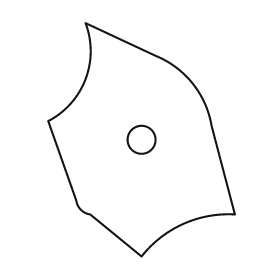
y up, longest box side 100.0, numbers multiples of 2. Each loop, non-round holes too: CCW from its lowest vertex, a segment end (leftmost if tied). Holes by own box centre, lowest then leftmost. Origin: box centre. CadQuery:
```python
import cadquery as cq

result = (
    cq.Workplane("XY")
    .moveTo(0.0, -50.0)
    .threePointArc((18.0, -36.0), (40.0, -32.0))
    .lineTo(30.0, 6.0)
    .threePointArc((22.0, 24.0), (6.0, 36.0))
    .lineTo(-24.0, 50.0)
    .threePointArc((-24.0, 26.0), (-40.0, 8.0))
    .lineTo(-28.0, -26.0)
    .threePointArc((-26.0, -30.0), (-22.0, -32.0))
    .close()
    .moveTo(0.0, 0.0)
    .circle(6.0)
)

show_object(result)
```